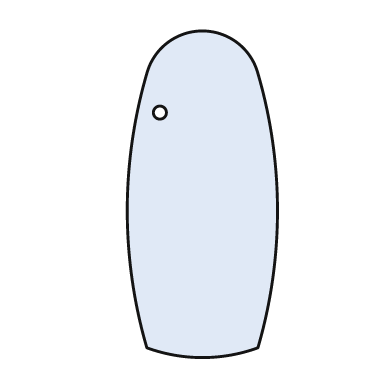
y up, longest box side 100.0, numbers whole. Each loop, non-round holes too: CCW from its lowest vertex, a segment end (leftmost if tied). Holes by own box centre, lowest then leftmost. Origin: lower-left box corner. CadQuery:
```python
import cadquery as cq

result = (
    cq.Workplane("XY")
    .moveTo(6.0, 3.0)
    .threePointArc((23.0, 0.0), (40.0, 3.0))
    .threePointArc((46.0, 45.0), (40.0, 87.0))
    .threePointArc((23.0, 100.0), (6.0, 87.0))
    .threePointArc((0.0, 45.0), (6.0, 3.0))
    .close()
    .moveTo(10.0, 75.0)
    .circle(2.0)
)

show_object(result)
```